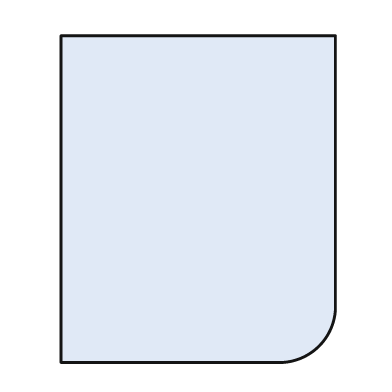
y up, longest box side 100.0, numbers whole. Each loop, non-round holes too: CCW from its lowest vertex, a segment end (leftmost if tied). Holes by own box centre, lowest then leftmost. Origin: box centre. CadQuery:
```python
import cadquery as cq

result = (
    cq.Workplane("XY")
    .moveTo(-42.0, -50.0)
    .lineTo(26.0, -50.0)
    .threePointArc((37.0, -45.0), (42.0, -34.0))
    .lineTo(42.0, 50.0)
    .lineTo(-42.0, 50.0)
    .close()
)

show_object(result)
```